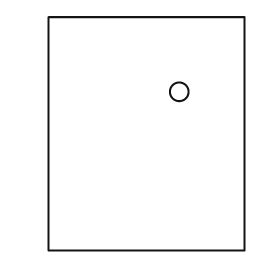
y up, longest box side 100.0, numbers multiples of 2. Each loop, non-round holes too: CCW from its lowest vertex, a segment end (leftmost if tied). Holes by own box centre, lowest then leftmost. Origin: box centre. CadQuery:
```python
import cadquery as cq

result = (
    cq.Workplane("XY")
    .moveTo(-42.0, -50.0)
    .lineTo(42.0, -50.0)
    .lineTo(42.0, 50.0)
    .lineTo(-42.0, 50.0)
    .close()
    .moveTo(14.0, 18.0)
    .circle(4.0)
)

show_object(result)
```